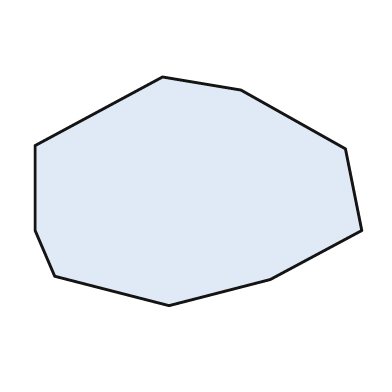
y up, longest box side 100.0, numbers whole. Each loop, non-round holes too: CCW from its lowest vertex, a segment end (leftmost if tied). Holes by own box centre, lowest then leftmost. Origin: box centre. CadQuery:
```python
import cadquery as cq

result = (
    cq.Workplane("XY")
    .moveTo(-9.0, -35.0)
    .lineTo(22.0, -27.0)
    .lineTo(50.0, -12.0)
    .lineTo(45.0, 13.0)
    .lineTo(13.0, 31.0)
    .lineTo(-11.0, 35.0)
    .lineTo(-50.0, 14.0)
    .lineTo(-50.0, -12.0)
    .lineTo(-44.0, -26.0)
    .close()
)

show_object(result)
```